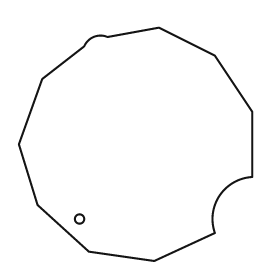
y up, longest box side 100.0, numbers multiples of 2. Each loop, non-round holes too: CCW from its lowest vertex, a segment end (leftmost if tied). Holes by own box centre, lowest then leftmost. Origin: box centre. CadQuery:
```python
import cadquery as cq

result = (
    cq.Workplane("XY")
    .moveTo(8.0, -50.0)
    .lineTo(34.0, -38.0)
    .threePointArc((36.0, -22.0), (50.0, -14.0))
    .lineTo(50.0, 14.0)
    .lineTo(34.0, 38.0)
    .lineTo(10.0, 50.0)
    .lineTo(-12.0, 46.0)
    .threePointArc((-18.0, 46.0), (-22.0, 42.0))
    .lineTo(-40.0, 28.0)
    .lineTo(-50.0, 0.0)
    .lineTo(-42.0, -26.0)
    .lineTo(-20.0, -46.0)
    .close()
    .moveTo(-24.0, -32.0)
    .circle(2.0)
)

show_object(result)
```